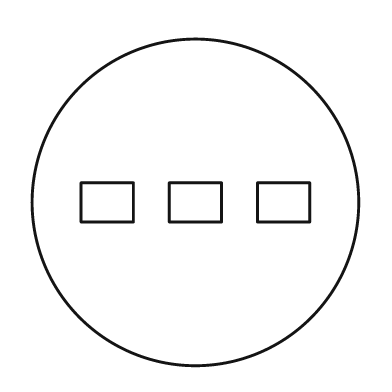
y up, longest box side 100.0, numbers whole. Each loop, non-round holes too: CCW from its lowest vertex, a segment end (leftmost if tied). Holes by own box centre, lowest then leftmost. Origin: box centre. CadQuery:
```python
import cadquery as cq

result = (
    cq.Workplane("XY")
    .moveTo(0.0, 0.0)
    .circle(50.0)
    .moveTo(-35.0, -6.0)
    .lineTo(-19.0, -6.0)
    .lineTo(-19.0, 6.0)
    .lineTo(-35.0, 6.0)
    .close()
    .moveTo(-8.0, -6.0)
    .lineTo(8.0, -6.0)
    .lineTo(8.0, 6.0)
    .lineTo(-8.0, 6.0)
    .close()
    .moveTo(19.0, -6.0)
    .lineTo(35.0, -6.0)
    .lineTo(35.0, 6.0)
    .lineTo(19.0, 6.0)
    .close()
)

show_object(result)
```